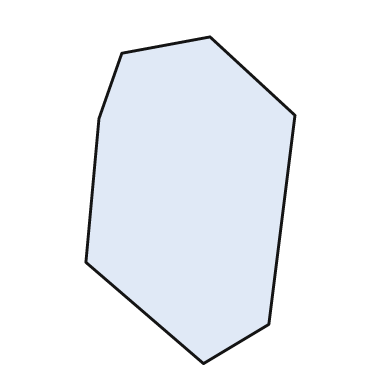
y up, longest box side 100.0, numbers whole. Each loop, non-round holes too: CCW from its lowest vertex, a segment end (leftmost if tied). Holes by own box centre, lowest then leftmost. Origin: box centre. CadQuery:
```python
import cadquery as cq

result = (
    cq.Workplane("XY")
    .moveTo(4.0, -50.0)
    .lineTo(24.0, -38.0)
    .lineTo(32.0, 26.0)
    .lineTo(6.0, 50.0)
    .lineTo(-21.0, 45.0)
    .lineTo(-28.0, 25.0)
    .lineTo(-32.0, -19.0)
    .close()
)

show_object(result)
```